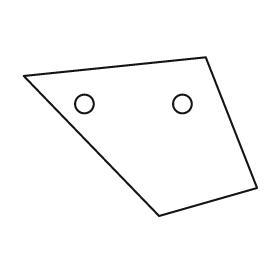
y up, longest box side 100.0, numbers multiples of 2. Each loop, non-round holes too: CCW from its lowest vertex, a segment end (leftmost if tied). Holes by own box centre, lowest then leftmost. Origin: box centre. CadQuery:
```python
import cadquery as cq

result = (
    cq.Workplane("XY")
    .moveTo(8.0, -34.0)
    .lineTo(50.0, -22.0)
    .lineTo(28.0, 34.0)
    .lineTo(-50.0, 26.0)
    .close()
    .moveTo(-24.0, 14.0)
    .circle(4.0)
    .moveTo(18.0, 14.0)
    .circle(4.0)
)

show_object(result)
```